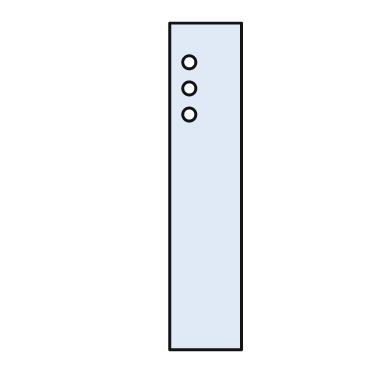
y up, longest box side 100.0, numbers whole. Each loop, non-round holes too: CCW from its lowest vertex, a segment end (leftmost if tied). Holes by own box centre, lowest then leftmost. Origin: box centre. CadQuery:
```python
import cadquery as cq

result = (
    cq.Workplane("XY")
    .moveTo(-11.0, -50.0)
    .lineTo(11.0, -50.0)
    .lineTo(11.0, 50.0)
    .lineTo(-11.0, 50.0)
    .close()
    .moveTo(-5.0, 22.0)
    .circle(2.0)
    .moveTo(-5.0, 30.0)
    .circle(2.0)
    .moveTo(-5.0, 38.0)
    .circle(2.0)
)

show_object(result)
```